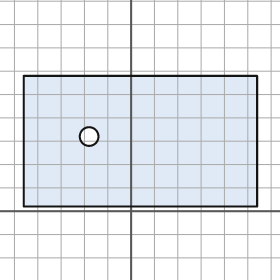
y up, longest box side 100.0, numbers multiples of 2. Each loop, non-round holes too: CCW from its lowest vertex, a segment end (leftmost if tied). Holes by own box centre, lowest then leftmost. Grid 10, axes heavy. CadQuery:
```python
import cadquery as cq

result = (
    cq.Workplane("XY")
    .moveTo(-46.0, 2.0)
    .lineTo(54.0, 2.0)
    .lineTo(54.0, 58.0)
    .lineTo(-46.0, 58.0)
    .close()
    .moveTo(-18.0, 32.0)
    .circle(4.0)
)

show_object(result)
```